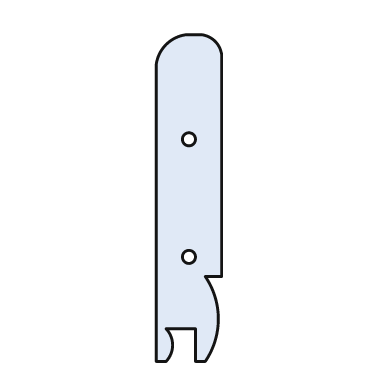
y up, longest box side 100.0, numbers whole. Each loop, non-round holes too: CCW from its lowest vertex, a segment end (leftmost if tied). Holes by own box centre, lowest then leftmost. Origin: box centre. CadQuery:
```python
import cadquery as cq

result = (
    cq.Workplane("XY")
    .moveTo(-10.0, -50.0)
    .lineTo(-7.0, -50.0)
    .threePointArc((-5.0, -45.0), (-7.0, -40.0))
    .lineTo(2.0, -40.0)
    .lineTo(2.0, -50.0)
    .lineTo(5.0, -50.0)
    .threePointArc((9.0, -37.0), (5.0, -24.0))
    .lineTo(10.0, -24.0)
    .lineTo(10.0, 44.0)
    .threePointArc((8.0, 48.0), (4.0, 50.0))
    .lineTo(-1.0, 50.0)
    .threePointArc((-7.0, 47.0), (-10.0, 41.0))
    .close()
    .moveTo(0.0, -18.0)
    .circle(2.0)
    .moveTo(0.0, 18.0)
    .circle(2.0)
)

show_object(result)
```